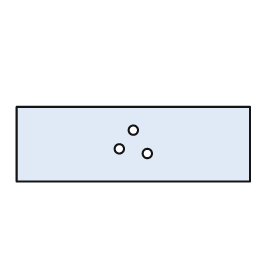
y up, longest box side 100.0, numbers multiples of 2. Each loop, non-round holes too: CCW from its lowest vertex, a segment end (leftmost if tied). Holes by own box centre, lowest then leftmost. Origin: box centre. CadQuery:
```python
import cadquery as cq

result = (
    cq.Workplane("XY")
    .moveTo(-50.0, -16.0)
    .lineTo(50.0, -16.0)
    .lineTo(50.0, 16.0)
    .lineTo(-50.0, 16.0)
    .close()
    .moveTo(6.0, -4.0)
    .circle(2.0)
    .moveTo(-6.0, -2.0)
    .circle(2.0)
    .moveTo(0.0, 6.0)
    .circle(2.0)
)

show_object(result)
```